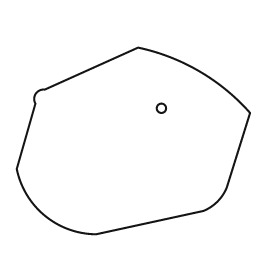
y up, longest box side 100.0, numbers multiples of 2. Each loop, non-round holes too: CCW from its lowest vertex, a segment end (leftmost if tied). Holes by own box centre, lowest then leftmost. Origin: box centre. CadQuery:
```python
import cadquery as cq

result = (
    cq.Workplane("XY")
    .moveTo(-16.0, -40.0)
    .lineTo(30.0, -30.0)
    .threePointArc((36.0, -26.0), (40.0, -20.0))
    .lineTo(50.0, 12.0)
    .threePointArc((28.0, 30.0), (2.0, 40.0))
    .lineTo(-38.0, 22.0)
    .threePointArc((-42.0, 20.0), (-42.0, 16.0))
    .lineTo(-50.0, -12.0)
    .threePointArc((-38.0, -32.0), (-16.0, -40.0))
    .close()
    .moveTo(12.0, 14.0)
    .circle(2.0)
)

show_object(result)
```